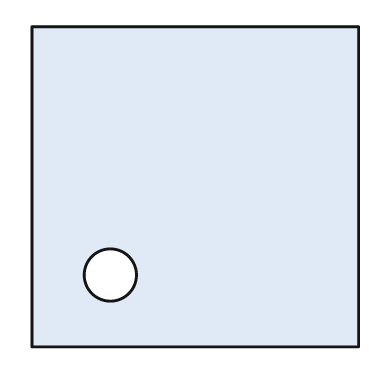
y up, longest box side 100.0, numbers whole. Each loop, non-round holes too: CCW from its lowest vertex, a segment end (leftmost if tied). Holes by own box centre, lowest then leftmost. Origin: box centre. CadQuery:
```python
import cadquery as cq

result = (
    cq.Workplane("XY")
    .moveTo(-50.0, -49.0)
    .lineTo(50.0, -49.0)
    .lineTo(50.0, 49.0)
    .lineTo(-50.0, 49.0)
    .close()
    .moveTo(-26.0, -27.0)
    .circle(8.0)
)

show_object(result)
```